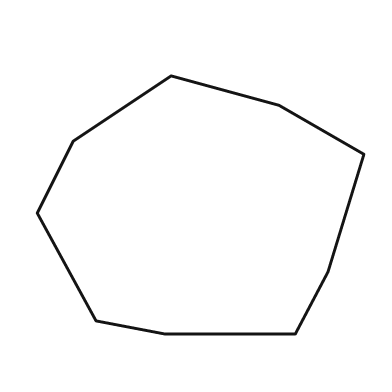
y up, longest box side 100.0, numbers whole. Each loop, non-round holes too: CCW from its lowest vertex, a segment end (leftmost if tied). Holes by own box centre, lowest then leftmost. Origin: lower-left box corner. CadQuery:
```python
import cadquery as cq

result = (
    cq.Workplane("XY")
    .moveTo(39.0, 0.0)
    .lineTo(79.0, 0.0)
    .lineTo(89.0, 19.0)
    .lineTo(100.0, 55.0)
    .lineTo(74.0, 70.0)
    .lineTo(41.0, 79.0)
    .lineTo(11.0, 59.0)
    .lineTo(0.0, 37.0)
    .lineTo(18.0, 4.0)
    .close()
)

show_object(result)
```